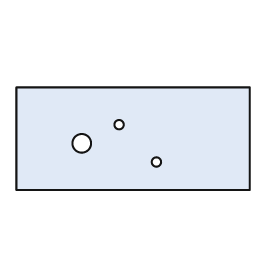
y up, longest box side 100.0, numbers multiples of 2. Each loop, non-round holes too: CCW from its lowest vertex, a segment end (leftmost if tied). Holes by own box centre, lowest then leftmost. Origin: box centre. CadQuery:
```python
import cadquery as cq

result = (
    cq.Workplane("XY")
    .moveTo(-50.0, -22.0)
    .lineTo(50.0, -22.0)
    .lineTo(50.0, 22.0)
    .lineTo(-50.0, 22.0)
    .close()
    .moveTo(10.0, -10.0)
    .circle(2.0)
    .moveTo(-22.0, -2.0)
    .circle(4.0)
    .moveTo(-6.0, 6.0)
    .circle(2.0)
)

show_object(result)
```